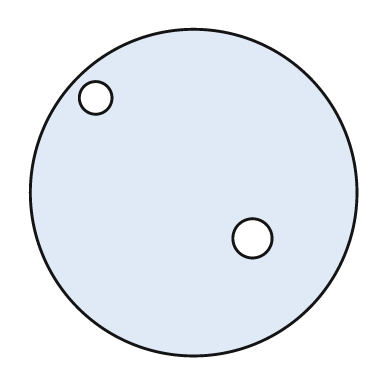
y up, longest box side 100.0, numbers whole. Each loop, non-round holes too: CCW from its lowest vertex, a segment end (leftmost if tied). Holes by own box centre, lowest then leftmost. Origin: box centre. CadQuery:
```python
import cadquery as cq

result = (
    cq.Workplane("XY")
    .moveTo(0.0, 0.0)
    .circle(50.0)
    .moveTo(18.0, -14.0)
    .circle(6.0)
    .moveTo(-30.0, 29.0)
    .circle(5.0)
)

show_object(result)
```